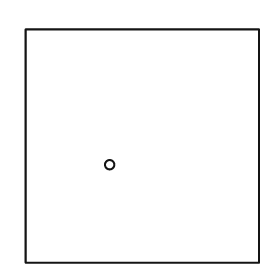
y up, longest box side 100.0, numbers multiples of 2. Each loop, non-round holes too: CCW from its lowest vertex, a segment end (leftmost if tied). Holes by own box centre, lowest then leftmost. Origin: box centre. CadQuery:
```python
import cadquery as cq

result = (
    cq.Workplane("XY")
    .moveTo(-50.0, -50.0)
    .lineTo(50.0, -50.0)
    .lineTo(50.0, 50.0)
    .lineTo(-50.0, 50.0)
    .close()
    .moveTo(-14.0, -8.0)
    .circle(2.0)
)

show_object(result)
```